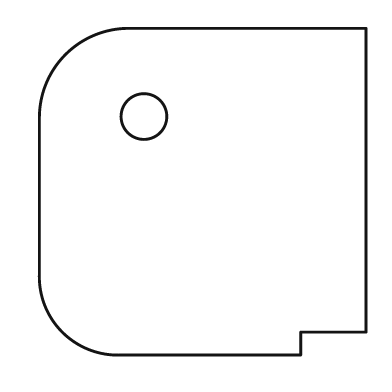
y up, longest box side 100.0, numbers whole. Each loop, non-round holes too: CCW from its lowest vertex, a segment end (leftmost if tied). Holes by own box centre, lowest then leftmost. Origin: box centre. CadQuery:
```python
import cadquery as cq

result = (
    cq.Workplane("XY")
    .moveTo(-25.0, -50.0)
    .lineTo(30.0, -50.0)
    .lineTo(30.0, -43.0)
    .lineTo(50.0, -43.0)
    .lineTo(50.0, 50.0)
    .lineTo(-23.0, 50.0)
    .threePointArc((-42.0, 42.0), (-50.0, 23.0))
    .lineTo(-50.0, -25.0)
    .threePointArc((-43.0, -43.0), (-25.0, -50.0))
    .close()
    .moveTo(-18.0, 23.0)
    .circle(7.0)
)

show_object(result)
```